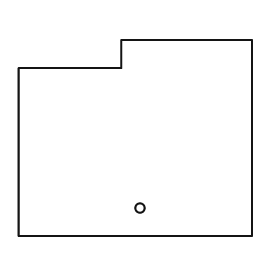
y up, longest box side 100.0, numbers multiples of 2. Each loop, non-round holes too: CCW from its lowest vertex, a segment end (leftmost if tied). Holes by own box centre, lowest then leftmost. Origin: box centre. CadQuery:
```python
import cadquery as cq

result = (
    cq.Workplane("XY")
    .moveTo(-50.0, -42.0)
    .lineTo(50.0, -42.0)
    .lineTo(50.0, 42.0)
    .lineTo(-6.0, 42.0)
    .lineTo(-6.0, 30.0)
    .lineTo(-50.0, 30.0)
    .close()
    .moveTo(2.0, -30.0)
    .circle(2.0)
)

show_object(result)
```